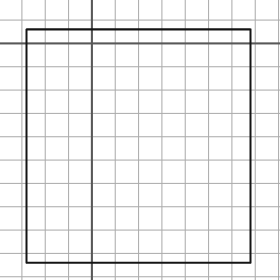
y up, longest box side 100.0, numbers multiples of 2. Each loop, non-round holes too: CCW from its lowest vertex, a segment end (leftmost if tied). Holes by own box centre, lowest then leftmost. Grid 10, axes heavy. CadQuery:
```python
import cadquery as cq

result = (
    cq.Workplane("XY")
    .moveTo(-28.0, -94.0)
    .lineTo(68.0, -94.0)
    .lineTo(68.0, 6.0)
    .lineTo(-28.0, 6.0)
    .close()
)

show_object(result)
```